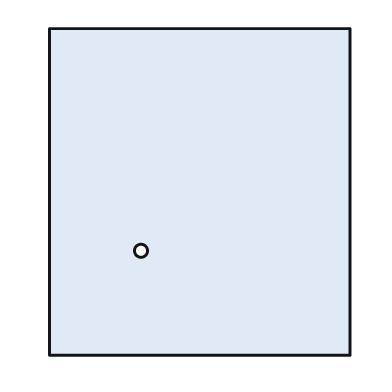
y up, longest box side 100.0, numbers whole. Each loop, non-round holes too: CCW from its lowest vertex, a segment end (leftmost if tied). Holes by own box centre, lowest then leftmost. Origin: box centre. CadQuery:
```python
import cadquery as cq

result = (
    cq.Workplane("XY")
    .moveTo(-46.0, -50.0)
    .lineTo(46.0, -50.0)
    .lineTo(46.0, 50.0)
    .lineTo(-46.0, 50.0)
    .close()
    .moveTo(-18.0, -18.0)
    .circle(2.0)
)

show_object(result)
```